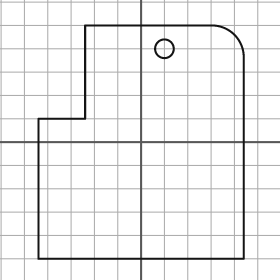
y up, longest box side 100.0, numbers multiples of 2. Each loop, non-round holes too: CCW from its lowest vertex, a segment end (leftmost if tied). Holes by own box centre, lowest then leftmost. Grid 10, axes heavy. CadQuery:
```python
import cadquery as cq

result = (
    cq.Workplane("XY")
    .moveTo(-44.0, -50.0)
    .lineTo(44.0, -50.0)
    .lineTo(44.0, 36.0)
    .threePointArc((40.0, 46.0), (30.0, 50.0))
    .lineTo(-24.0, 50.0)
    .lineTo(-24.0, 10.0)
    .lineTo(-44.0, 10.0)
    .close()
    .moveTo(10.0, 40.0)
    .circle(4.0)
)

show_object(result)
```